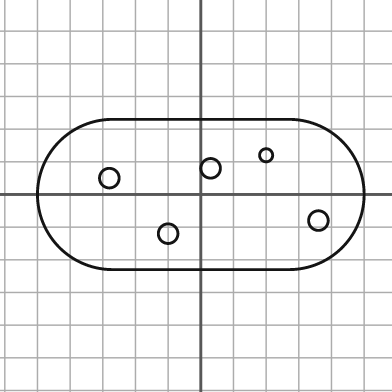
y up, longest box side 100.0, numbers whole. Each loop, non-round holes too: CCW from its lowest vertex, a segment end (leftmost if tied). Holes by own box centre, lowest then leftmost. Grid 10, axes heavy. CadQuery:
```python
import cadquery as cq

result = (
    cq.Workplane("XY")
    .moveTo(-27.0, -23.0)
    .lineTo(27.0, -23.0)
    .threePointArc((50.0, 0.0), (27.0, 23.0))
    .lineTo(-27.0, 23.0)
    .threePointArc((-50.0, 0.0), (-27.0, -23.0))
    .close()
    .moveTo(-10.0, -12.0)
    .circle(3.0)
    .moveTo(36.0, -8.0)
    .circle(3.0)
    .moveTo(-28.0, 5.0)
    .circle(3.0)
    .moveTo(3.0, 8.0)
    .circle(3.0)
    .moveTo(20.0, 12.0)
    .circle(2.0)
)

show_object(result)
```